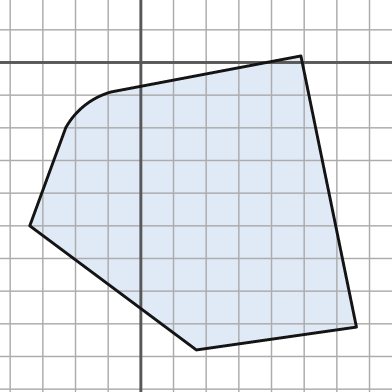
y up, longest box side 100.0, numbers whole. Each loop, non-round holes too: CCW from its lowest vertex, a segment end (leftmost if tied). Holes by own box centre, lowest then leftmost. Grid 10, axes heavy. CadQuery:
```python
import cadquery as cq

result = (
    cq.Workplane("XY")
    .moveTo(17.0, -88.0)
    .lineTo(66.0, -81.0)
    .lineTo(49.0, 2.0)
    .lineTo(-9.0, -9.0)
    .threePointArc((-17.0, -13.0), (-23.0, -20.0))
    .lineTo(-34.0, -50.0)
    .close()
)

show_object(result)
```